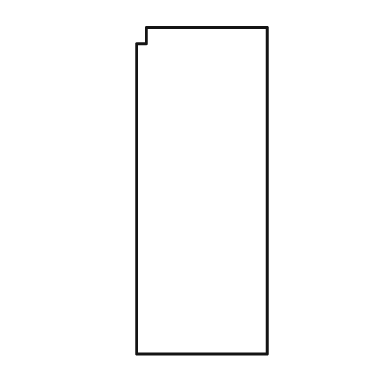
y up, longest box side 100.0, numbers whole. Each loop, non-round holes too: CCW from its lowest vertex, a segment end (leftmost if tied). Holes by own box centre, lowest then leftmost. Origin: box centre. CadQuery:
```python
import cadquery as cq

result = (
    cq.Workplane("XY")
    .moveTo(-20.0, -50.0)
    .lineTo(20.0, -50.0)
    .lineTo(20.0, 50.0)
    .lineTo(-17.0, 50.0)
    .lineTo(-17.0, 45.0)
    .lineTo(-20.0, 45.0)
    .close()
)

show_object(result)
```